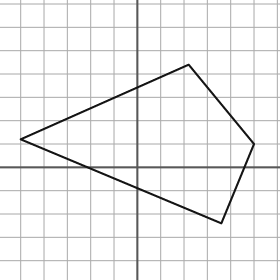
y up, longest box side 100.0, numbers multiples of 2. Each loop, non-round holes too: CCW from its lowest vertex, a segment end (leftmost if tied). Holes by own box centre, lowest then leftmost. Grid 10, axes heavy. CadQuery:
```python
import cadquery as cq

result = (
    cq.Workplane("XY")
    .moveTo(36.0, -24.0)
    .lineTo(50.0, 10.0)
    .lineTo(22.0, 44.0)
    .lineTo(-50.0, 12.0)
    .close()
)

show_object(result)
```